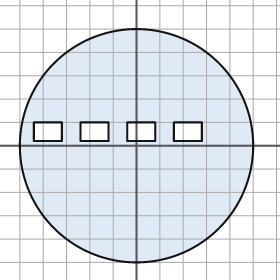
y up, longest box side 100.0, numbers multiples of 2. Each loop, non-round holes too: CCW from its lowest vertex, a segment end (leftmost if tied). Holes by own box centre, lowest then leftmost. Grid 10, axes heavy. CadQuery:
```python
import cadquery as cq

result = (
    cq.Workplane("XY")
    .moveTo(0.0, 0.0)
    .circle(50.0)
    .moveTo(-44.0, 2.0)
    .lineTo(-32.0, 2.0)
    .lineTo(-32.0, 10.0)
    .lineTo(-44.0, 10.0)
    .close()
    .moveTo(-24.0, 2.0)
    .lineTo(-12.0, 2.0)
    .lineTo(-12.0, 10.0)
    .lineTo(-24.0, 10.0)
    .close()
    .moveTo(-4.0, 2.0)
    .lineTo(8.0, 2.0)
    .lineTo(8.0, 10.0)
    .lineTo(-4.0, 10.0)
    .close()
    .moveTo(16.0, 2.0)
    .lineTo(28.0, 2.0)
    .lineTo(28.0, 10.0)
    .lineTo(16.0, 10.0)
    .close()
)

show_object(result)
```